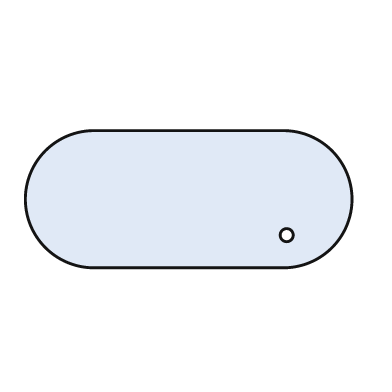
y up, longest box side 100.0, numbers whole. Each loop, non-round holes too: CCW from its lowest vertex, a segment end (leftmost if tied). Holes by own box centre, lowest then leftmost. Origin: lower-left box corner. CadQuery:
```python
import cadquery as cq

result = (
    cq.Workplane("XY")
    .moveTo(21.0, 0.0)
    .lineTo(79.0, 0.0)
    .threePointArc((100.0, 21.0), (79.0, 42.0))
    .lineTo(21.0, 42.0)
    .threePointArc((0.0, 21.0), (21.0, 0.0))
    .close()
    .moveTo(80.0, 10.0)
    .circle(2.0)
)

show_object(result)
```